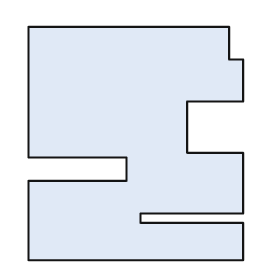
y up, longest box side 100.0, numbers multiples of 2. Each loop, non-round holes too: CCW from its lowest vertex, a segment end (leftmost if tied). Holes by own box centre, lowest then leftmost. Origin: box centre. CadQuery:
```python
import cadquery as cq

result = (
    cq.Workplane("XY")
    .moveTo(-46.0, -50.0)
    .lineTo(46.0, -50.0)
    .lineTo(46.0, -34.0)
    .lineTo(2.0, -34.0)
    .lineTo(2.0, -30.0)
    .lineTo(46.0, -30.0)
    .lineTo(46.0, -4.0)
    .lineTo(22.0, -4.0)
    .lineTo(22.0, 18.0)
    .lineTo(46.0, 18.0)
    .lineTo(46.0, 36.0)
    .lineTo(40.0, 36.0)
    .lineTo(40.0, 50.0)
    .lineTo(-46.0, 50.0)
    .lineTo(-46.0, -6.0)
    .lineTo(-4.0, -6.0)
    .lineTo(-4.0, -16.0)
    .lineTo(-46.0, -16.0)
    .close()
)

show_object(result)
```